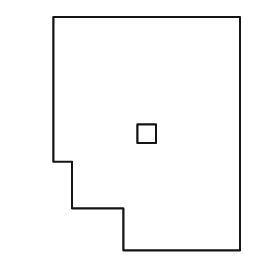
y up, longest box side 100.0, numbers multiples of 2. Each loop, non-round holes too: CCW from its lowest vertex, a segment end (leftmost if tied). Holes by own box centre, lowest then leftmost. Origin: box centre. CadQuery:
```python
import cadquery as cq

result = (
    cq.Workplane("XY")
    .moveTo(-10.0, -50.0)
    .lineTo(40.0, -50.0)
    .lineTo(40.0, 50.0)
    .lineTo(-40.0, 50.0)
    .lineTo(-40.0, -12.0)
    .lineTo(-32.0, -12.0)
    .lineTo(-32.0, -32.0)
    .lineTo(-10.0, -32.0)
    .close()
    .moveTo(-4.0, -4.0)
    .lineTo(4.0, -4.0)
    .lineTo(4.0, 4.0)
    .lineTo(-4.0, 4.0)
    .close()
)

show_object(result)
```